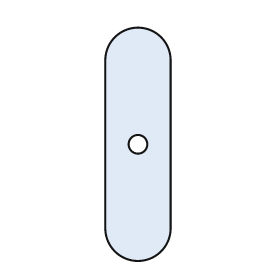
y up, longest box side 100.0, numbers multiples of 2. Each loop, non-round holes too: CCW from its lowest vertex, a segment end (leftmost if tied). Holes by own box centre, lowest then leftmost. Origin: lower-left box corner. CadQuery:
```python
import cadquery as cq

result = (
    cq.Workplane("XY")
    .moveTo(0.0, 14.0)
    .threePointArc((14.0, 0.0), (28.0, 14.0))
    .lineTo(28.0, 86.0)
    .threePointArc((14.0, 100.0), (0.0, 86.0))
    .close()
    .moveTo(14.0, 50.0)
    .circle(4.0)
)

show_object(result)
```